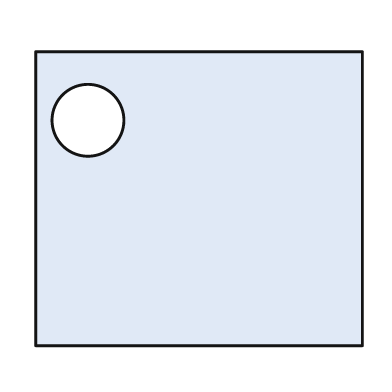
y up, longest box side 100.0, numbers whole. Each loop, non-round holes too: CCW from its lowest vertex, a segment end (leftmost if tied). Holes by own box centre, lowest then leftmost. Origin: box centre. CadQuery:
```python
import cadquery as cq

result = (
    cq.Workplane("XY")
    .moveTo(-50.0, -45.0)
    .lineTo(50.0, -45.0)
    .lineTo(50.0, 45.0)
    .lineTo(-50.0, 45.0)
    .close()
    .moveTo(-34.0, 24.0)
    .circle(11.0)
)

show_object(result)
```